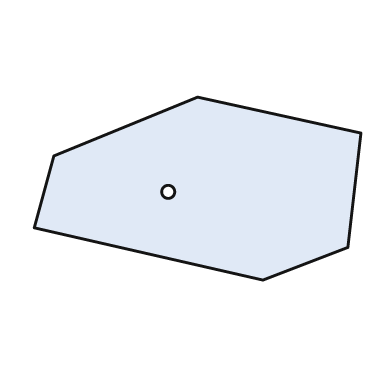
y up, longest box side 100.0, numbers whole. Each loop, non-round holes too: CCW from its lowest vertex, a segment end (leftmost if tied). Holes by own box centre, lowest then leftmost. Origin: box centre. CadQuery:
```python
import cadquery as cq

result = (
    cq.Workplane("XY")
    .moveTo(20.0, -28.0)
    .lineTo(46.0, -18.0)
    .lineTo(50.0, 17.0)
    .lineTo(0.0, 28.0)
    .lineTo(-44.0, 10.0)
    .lineTo(-50.0, -12.0)
    .close()
    .moveTo(-9.0, -1.0)
    .circle(2.0)
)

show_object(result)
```